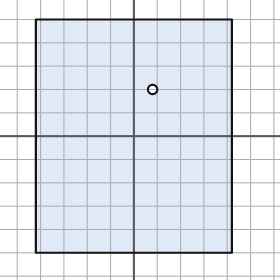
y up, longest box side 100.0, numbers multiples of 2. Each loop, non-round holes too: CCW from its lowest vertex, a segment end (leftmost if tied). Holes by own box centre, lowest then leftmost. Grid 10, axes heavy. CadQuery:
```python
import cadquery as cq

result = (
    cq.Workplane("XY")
    .moveTo(-42.0, -50.0)
    .lineTo(42.0, -50.0)
    .lineTo(42.0, 50.0)
    .lineTo(-42.0, 50.0)
    .close()
    .moveTo(8.0, 20.0)
    .circle(2.0)
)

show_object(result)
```